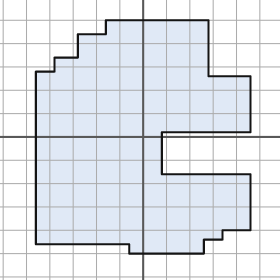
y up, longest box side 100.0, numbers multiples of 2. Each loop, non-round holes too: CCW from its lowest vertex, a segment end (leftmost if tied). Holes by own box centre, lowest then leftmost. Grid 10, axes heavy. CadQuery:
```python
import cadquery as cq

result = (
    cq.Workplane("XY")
    .moveTo(-6.0, -50.0)
    .lineTo(26.0, -50.0)
    .lineTo(26.0, -44.0)
    .lineTo(34.0, -44.0)
    .lineTo(34.0, -40.0)
    .lineTo(46.0, -40.0)
    .lineTo(46.0, -16.0)
    .lineTo(8.0, -16.0)
    .lineTo(8.0, 2.0)
    .lineTo(46.0, 2.0)
    .lineTo(46.0, 26.0)
    .lineTo(28.0, 26.0)
    .lineTo(28.0, 50.0)
    .lineTo(-16.0, 50.0)
    .lineTo(-16.0, 44.0)
    .lineTo(-28.0, 44.0)
    .lineTo(-28.0, 34.0)
    .lineTo(-38.0, 34.0)
    .lineTo(-38.0, 28.0)
    .lineTo(-46.0, 28.0)
    .lineTo(-46.0, -46.0)
    .lineTo(-6.0, -46.0)
    .close()
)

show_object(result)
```